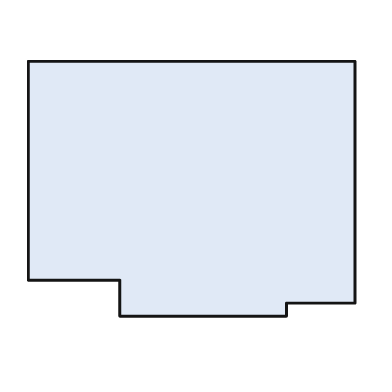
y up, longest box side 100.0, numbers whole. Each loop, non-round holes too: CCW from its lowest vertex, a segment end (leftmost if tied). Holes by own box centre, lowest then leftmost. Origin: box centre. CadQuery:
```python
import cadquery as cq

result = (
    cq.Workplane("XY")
    .moveTo(-22.0, -39.0)
    .lineTo(29.0, -39.0)
    .lineTo(29.0, -35.0)
    .lineTo(50.0, -35.0)
    .lineTo(50.0, 39.0)
    .lineTo(-50.0, 39.0)
    .lineTo(-50.0, -28.0)
    .lineTo(-22.0, -28.0)
    .close()
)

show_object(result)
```